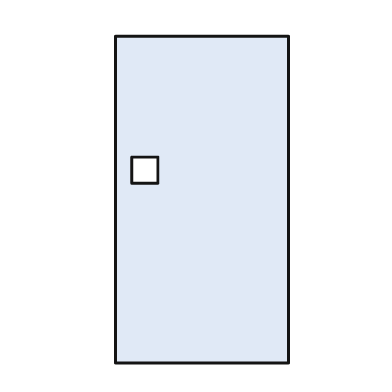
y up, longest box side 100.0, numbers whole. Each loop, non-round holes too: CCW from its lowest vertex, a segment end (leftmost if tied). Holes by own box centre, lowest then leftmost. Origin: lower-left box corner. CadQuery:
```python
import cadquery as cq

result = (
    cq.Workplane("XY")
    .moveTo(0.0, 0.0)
    .lineTo(53.0, 0.0)
    .lineTo(53.0, 100.0)
    .lineTo(0.0, 100.0)
    .close()
    .moveTo(5.0, 55.0)
    .lineTo(13.0, 55.0)
    .lineTo(13.0, 63.0)
    .lineTo(5.0, 63.0)
    .close()
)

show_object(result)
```